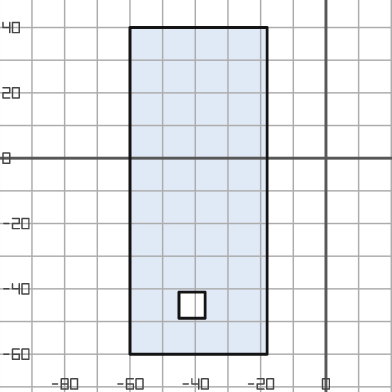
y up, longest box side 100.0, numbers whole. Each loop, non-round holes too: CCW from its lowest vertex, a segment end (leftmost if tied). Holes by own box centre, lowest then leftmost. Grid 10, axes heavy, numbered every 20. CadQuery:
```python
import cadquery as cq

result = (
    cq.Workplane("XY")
    .moveTo(-60.0, -60.0)
    .lineTo(-18.0, -60.0)
    .lineTo(-18.0, 40.0)
    .lineTo(-60.0, 40.0)
    .close()
    .moveTo(-45.0, -49.0)
    .lineTo(-37.0, -49.0)
    .lineTo(-37.0, -41.0)
    .lineTo(-45.0, -41.0)
    .close()
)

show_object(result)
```